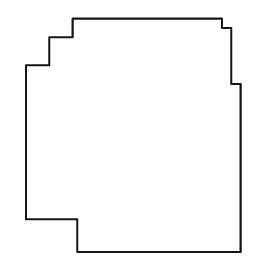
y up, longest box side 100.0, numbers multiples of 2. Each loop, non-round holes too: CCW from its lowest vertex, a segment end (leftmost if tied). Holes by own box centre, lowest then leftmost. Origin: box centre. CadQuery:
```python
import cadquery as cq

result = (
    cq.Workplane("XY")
    .moveTo(-24.0, -50.0)
    .lineTo(46.0, -50.0)
    .lineTo(46.0, 22.0)
    .lineTo(42.0, 22.0)
    .lineTo(42.0, 46.0)
    .lineTo(38.0, 46.0)
    .lineTo(38.0, 50.0)
    .lineTo(-26.0, 50.0)
    .lineTo(-26.0, 42.0)
    .lineTo(-36.0, 42.0)
    .lineTo(-36.0, 30.0)
    .lineTo(-46.0, 30.0)
    .lineTo(-46.0, -36.0)
    .lineTo(-24.0, -36.0)
    .close()
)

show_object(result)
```